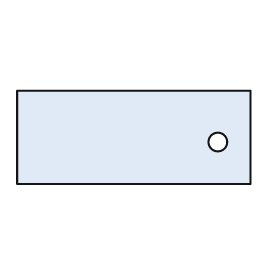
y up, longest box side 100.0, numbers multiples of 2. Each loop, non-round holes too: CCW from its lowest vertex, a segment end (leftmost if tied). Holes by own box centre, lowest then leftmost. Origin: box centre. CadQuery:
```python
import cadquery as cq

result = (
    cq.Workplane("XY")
    .moveTo(-50.0, -20.0)
    .lineTo(50.0, -20.0)
    .lineTo(50.0, 20.0)
    .lineTo(-50.0, 20.0)
    .close()
    .moveTo(36.0, -2.0)
    .circle(4.0)
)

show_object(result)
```